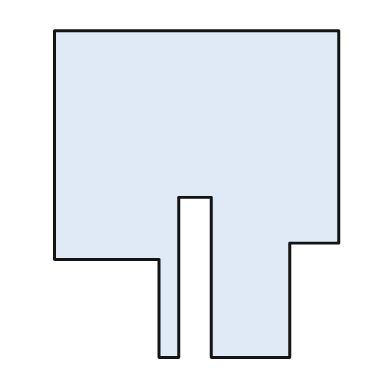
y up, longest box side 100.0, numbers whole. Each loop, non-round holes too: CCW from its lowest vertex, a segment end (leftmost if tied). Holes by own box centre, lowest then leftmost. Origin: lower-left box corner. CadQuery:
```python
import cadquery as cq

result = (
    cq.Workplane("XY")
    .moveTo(32.0, 0.0)
    .lineTo(38.0, 0.0)
    .lineTo(38.0, 49.0)
    .lineTo(48.0, 49.0)
    .lineTo(48.0, 0.0)
    .lineTo(72.0, 0.0)
    .lineTo(72.0, 35.0)
    .lineTo(87.0, 35.0)
    .lineTo(87.0, 100.0)
    .lineTo(0.0, 100.0)
    .lineTo(0.0, 30.0)
    .lineTo(32.0, 30.0)
    .close()
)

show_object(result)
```